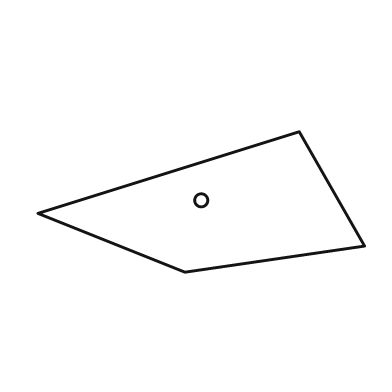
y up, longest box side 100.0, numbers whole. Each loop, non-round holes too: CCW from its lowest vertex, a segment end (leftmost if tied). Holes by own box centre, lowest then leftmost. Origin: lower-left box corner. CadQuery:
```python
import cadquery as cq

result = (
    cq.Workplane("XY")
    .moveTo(45.0, 0.0)
    .lineTo(100.0, 8.0)
    .lineTo(80.0, 43.0)
    .lineTo(0.0, 18.0)
    .close()
    .moveTo(50.0, 22.0)
    .circle(2.0)
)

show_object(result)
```